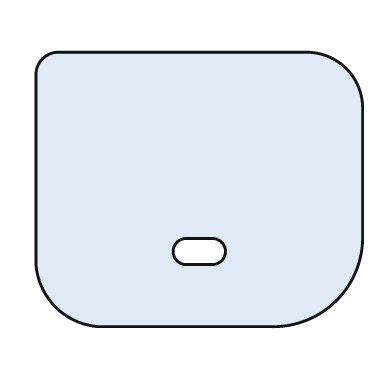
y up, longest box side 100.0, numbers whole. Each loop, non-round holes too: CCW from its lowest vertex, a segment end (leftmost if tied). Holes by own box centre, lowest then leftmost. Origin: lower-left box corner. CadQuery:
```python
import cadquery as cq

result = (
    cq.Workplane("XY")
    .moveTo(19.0, 0.0)
    .lineTo(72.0, 0.0)
    .threePointArc((92.0, 8.0), (100.0, 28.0))
    .lineTo(100.0, 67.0)
    .threePointArc((95.0, 79.0), (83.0, 84.0))
    .lineTo(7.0, 84.0)
    .threePointArc((2.0, 82.0), (0.0, 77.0))
    .lineTo(0.0, 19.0)
    .threePointArc((6.0, 6.0), (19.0, 0.0))
    .close()
    .moveTo(46.0, 19.0)
    .lineTo(54.0, 19.0)
    .threePointArc((58.0, 23.0), (54.0, 27.0))
    .lineTo(46.0, 27.0)
    .threePointArc((42.0, 23.0), (46.0, 19.0))
    .close()
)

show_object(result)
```